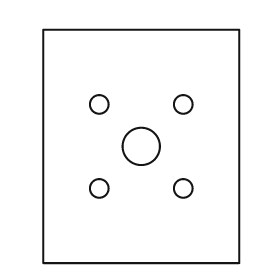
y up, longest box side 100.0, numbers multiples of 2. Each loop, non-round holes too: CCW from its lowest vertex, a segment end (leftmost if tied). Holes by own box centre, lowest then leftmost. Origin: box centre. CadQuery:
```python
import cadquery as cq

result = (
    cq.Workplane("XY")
    .moveTo(-42.0, -50.0)
    .lineTo(42.0, -50.0)
    .lineTo(42.0, 50.0)
    .lineTo(-42.0, 50.0)
    .close()
    .moveTo(-18.0, -18.0)
    .circle(4.0)
    .moveTo(18.0, -18.0)
    .circle(4.0)
    .moveTo(0.0, 0.0)
    .circle(8.0)
    .moveTo(-18.0, 18.0)
    .circle(4.0)
    .moveTo(18.0, 18.0)
    .circle(4.0)
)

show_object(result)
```